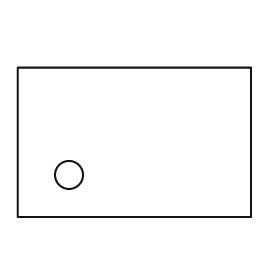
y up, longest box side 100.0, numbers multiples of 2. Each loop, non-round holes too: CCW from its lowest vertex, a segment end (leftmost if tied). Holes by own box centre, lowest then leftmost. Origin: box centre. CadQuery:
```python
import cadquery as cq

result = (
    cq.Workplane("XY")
    .moveTo(-50.0, -32.0)
    .lineTo(50.0, -32.0)
    .lineTo(50.0, 32.0)
    .lineTo(-50.0, 32.0)
    .close()
    .moveTo(-28.0, -14.0)
    .circle(6.0)
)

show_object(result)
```